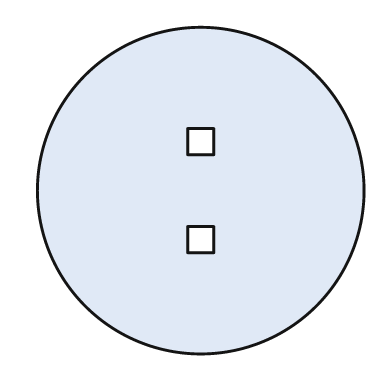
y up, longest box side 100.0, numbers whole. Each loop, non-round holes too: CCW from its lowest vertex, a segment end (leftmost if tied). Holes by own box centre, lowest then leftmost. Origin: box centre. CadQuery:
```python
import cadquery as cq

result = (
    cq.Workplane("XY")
    .moveTo(0.0, 0.0)
    .circle(50.0)
    .moveTo(-4.0, -19.0)
    .lineTo(4.0, -19.0)
    .lineTo(4.0, -11.0)
    .lineTo(-4.0, -11.0)
    .close()
    .moveTo(-4.0, 11.0)
    .lineTo(4.0, 11.0)
    .lineTo(4.0, 19.0)
    .lineTo(-4.0, 19.0)
    .close()
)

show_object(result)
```